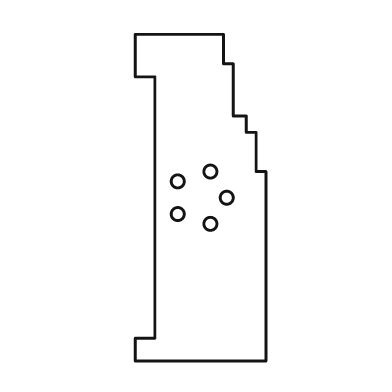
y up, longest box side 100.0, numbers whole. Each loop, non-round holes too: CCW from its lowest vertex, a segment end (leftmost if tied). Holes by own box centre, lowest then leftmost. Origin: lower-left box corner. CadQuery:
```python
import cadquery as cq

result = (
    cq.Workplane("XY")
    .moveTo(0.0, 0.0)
    .lineTo(40.0, 0.0)
    .lineTo(40.0, 58.0)
    .lineTo(37.0, 58.0)
    .lineTo(37.0, 70.0)
    .lineTo(34.0, 70.0)
    .lineTo(34.0, 75.0)
    .lineTo(30.0, 75.0)
    .lineTo(30.0, 91.0)
    .lineTo(27.0, 91.0)
    .lineTo(27.0, 100.0)
    .lineTo(0.0, 100.0)
    .lineTo(0.0, 87.0)
    .lineTo(6.0, 87.0)
    .lineTo(6.0, 7.0)
    .lineTo(0.0, 7.0)
    .close()
    .moveTo(23.0, 42.0)
    .circle(2.0)
    .moveTo(13.0, 45.0)
    .circle(2.0)
    .moveTo(28.0, 50.0)
    .circle(2.0)
    .moveTo(13.0, 55.0)
    .circle(2.0)
    .moveTo(23.0, 58.0)
    .circle(2.0)
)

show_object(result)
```